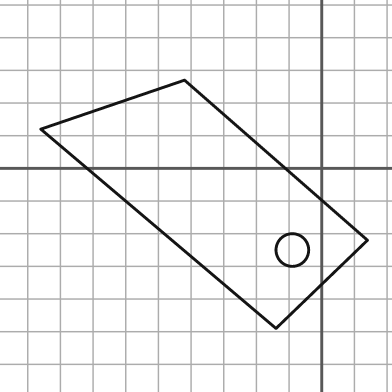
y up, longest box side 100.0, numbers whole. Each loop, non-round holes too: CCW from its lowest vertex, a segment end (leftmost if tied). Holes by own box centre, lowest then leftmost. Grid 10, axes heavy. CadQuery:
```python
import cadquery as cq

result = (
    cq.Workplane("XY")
    .moveTo(-14.0, -49.0)
    .lineTo(14.0, -22.0)
    .lineTo(-42.0, 27.0)
    .lineTo(-86.0, 12.0)
    .close()
    .moveTo(-9.0, -25.0)
    .circle(5.0)
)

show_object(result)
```